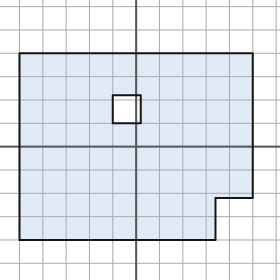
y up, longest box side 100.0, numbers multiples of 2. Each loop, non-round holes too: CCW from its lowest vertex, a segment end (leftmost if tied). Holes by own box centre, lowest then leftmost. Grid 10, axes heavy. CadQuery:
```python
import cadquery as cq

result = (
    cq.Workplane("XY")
    .moveTo(-50.0, -40.0)
    .lineTo(34.0, -40.0)
    .lineTo(34.0, -22.0)
    .lineTo(50.0, -22.0)
    .lineTo(50.0, 40.0)
    .lineTo(-50.0, 40.0)
    .close()
    .moveTo(-10.0, 10.0)
    .lineTo(2.0, 10.0)
    .lineTo(2.0, 22.0)
    .lineTo(-10.0, 22.0)
    .close()
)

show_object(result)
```